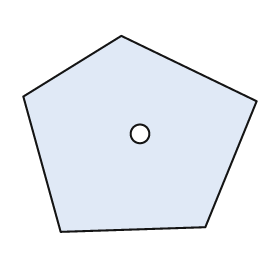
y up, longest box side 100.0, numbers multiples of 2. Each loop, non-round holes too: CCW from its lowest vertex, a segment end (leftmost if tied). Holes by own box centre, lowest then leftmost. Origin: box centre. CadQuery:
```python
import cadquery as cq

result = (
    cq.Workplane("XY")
    .moveTo(-34.0, -42.0)
    .lineTo(28.0, -40.0)
    .lineTo(50.0, 14.0)
    .lineTo(-8.0, 42.0)
    .lineTo(-50.0, 16.0)
    .close()
    .moveTo(0.0, 0.0)
    .circle(4.0)
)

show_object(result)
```